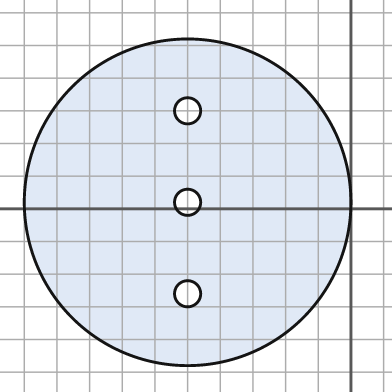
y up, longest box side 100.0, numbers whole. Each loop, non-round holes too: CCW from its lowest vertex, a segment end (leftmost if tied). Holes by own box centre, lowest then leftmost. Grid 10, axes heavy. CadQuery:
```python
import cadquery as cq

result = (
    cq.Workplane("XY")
    .moveTo(-50.0, 2.0)
    .circle(50.0)
    .moveTo(-50.0, -26.0)
    .circle(4.0)
    .moveTo(-50.0, 2.0)
    .circle(4.0)
    .moveTo(-50.0, 30.0)
    .circle(4.0)
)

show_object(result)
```